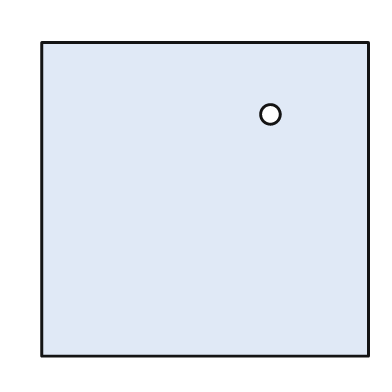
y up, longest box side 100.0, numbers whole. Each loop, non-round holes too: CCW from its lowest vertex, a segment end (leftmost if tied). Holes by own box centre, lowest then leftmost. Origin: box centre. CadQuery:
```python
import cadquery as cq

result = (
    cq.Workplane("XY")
    .moveTo(-50.0, -48.0)
    .lineTo(50.0, -48.0)
    .lineTo(50.0, 48.0)
    .lineTo(-50.0, 48.0)
    .close()
    .moveTo(20.0, 26.0)
    .circle(3.0)
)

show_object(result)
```